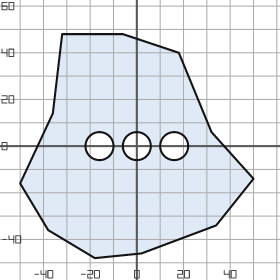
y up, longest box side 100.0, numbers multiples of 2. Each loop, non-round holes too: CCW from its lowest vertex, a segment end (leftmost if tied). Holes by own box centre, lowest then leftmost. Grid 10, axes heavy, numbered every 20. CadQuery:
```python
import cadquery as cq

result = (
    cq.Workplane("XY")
    .moveTo(-18.0, -48.0)
    .lineTo(2.0, -46.0)
    .lineTo(34.0, -34.0)
    .lineTo(50.0, -14.0)
    .lineTo(32.0, 6.0)
    .lineTo(18.0, 40.0)
    .lineTo(-6.0, 48.0)
    .lineTo(-32.0, 48.0)
    .lineTo(-36.0, 14.0)
    .lineTo(-50.0, -16.0)
    .lineTo(-38.0, -36.0)
    .close()
    .moveTo(-16.0, 0.0)
    .circle(6.0)
    .moveTo(0.0, 0.0)
    .circle(6.0)
    .moveTo(16.0, 0.0)
    .circle(6.0)
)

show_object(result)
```